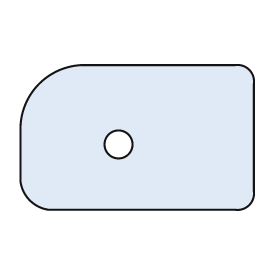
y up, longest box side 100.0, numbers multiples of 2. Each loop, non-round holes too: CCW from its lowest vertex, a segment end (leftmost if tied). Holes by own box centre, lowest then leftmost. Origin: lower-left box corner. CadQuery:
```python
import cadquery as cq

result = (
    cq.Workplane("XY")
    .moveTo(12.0, 0.0)
    .lineTo(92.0, 0.0)
    .threePointArc((98.0, 2.0), (100.0, 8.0))
    .lineTo(100.0, 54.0)
    .threePointArc((98.0, 60.0), (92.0, 62.0))
    .lineTo(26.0, 62.0)
    .threePointArc((8.0, 54.0), (0.0, 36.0))
    .lineTo(0.0, 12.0)
    .threePointArc((4.0, 4.0), (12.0, 0.0))
    .close()
    .moveTo(42.0, 28.0)
    .circle(6.0)
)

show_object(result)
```